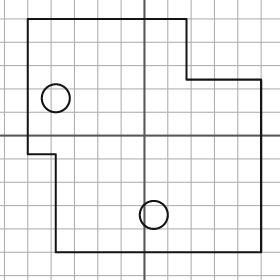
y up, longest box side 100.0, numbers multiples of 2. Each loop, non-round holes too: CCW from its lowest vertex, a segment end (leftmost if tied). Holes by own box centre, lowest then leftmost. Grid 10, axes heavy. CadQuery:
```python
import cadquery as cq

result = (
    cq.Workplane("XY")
    .moveTo(-38.0, -50.0)
    .lineTo(50.0, -50.0)
    .lineTo(50.0, 24.0)
    .lineTo(18.0, 24.0)
    .lineTo(18.0, 50.0)
    .lineTo(-50.0, 50.0)
    .lineTo(-50.0, -8.0)
    .lineTo(-38.0, -8.0)
    .close()
    .moveTo(4.0, -34.0)
    .circle(6.0)
    .moveTo(-38.0, 16.0)
    .circle(6.0)
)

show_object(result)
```